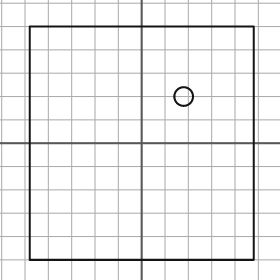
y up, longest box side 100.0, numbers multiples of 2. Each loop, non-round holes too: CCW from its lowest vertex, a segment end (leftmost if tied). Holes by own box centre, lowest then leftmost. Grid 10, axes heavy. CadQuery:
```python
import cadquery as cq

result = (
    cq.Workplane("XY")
    .moveTo(-48.0, -50.0)
    .lineTo(48.0, -50.0)
    .lineTo(48.0, 50.0)
    .lineTo(-48.0, 50.0)
    .close()
    .moveTo(18.0, 20.0)
    .circle(4.0)
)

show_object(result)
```